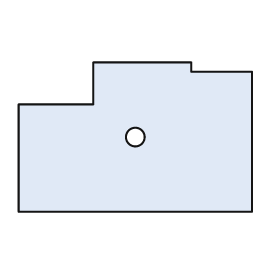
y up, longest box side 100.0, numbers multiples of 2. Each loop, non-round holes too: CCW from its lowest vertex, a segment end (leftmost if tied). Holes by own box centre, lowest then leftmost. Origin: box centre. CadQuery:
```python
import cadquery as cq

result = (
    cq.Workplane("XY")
    .moveTo(-50.0, -32.0)
    .lineTo(50.0, -32.0)
    .lineTo(50.0, 28.0)
    .lineTo(24.0, 28.0)
    .lineTo(24.0, 32.0)
    .lineTo(-18.0, 32.0)
    .lineTo(-18.0, 14.0)
    .lineTo(-50.0, 14.0)
    .close()
    .moveTo(0.0, 0.0)
    .circle(4.0)
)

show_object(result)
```